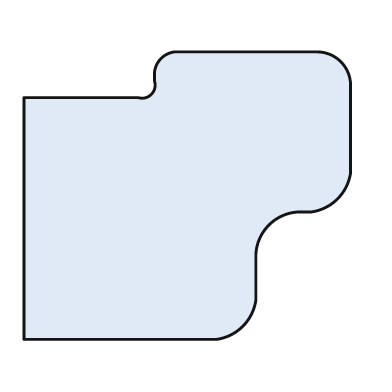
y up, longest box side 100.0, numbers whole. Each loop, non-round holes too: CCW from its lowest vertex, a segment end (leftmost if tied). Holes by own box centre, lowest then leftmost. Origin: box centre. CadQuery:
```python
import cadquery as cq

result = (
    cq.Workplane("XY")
    .moveTo(-50.0, -44.0)
    .lineTo(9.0, -44.0)
    .threePointArc((17.0, -40.0), (21.0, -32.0))
    .lineTo(21.0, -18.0)
    .threePointArc((25.0, -9.0), (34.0, -5.0))
    .lineTo(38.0, -5.0)
    .threePointArc((46.0, -1.0), (50.0, 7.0))
    .lineTo(50.0, 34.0)
    .threePointArc((47.0, 41.0), (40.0, 44.0))
    .lineTo(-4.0, 44.0)
    .threePointArc((-8.0, 42.0), (-10.0, 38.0))
    .lineTo(-10.0, 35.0)
    .threePointArc((-11.0, 31.0), (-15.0, 30.0))
    .lineTo(-50.0, 30.0)
    .close()
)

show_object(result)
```